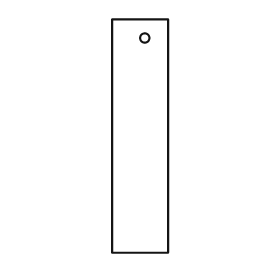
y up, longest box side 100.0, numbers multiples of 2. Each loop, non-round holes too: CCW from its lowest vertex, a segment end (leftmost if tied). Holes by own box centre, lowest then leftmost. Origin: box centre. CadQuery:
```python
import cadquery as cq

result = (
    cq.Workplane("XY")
    .moveTo(-12.0, -50.0)
    .lineTo(12.0, -50.0)
    .lineTo(12.0, 50.0)
    .lineTo(-12.0, 50.0)
    .close()
    .moveTo(2.0, 42.0)
    .circle(2.0)
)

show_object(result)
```